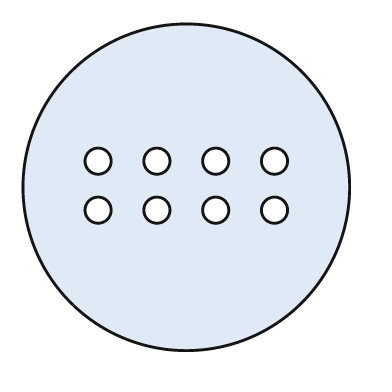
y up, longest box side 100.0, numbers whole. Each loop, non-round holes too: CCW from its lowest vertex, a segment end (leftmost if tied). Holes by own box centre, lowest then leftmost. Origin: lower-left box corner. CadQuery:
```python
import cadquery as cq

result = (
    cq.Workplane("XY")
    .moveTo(50.0, 50.0)
    .circle(50.0)
    .moveTo(23.0, 43.0)
    .circle(4.0)
    .moveTo(41.0, 43.0)
    .circle(4.0)
    .moveTo(59.0, 43.0)
    .circle(4.0)
    .moveTo(77.0, 43.0)
    .circle(4.0)
    .moveTo(23.0, 58.0)
    .circle(4.0)
    .moveTo(41.0, 58.0)
    .circle(4.0)
    .moveTo(59.0, 58.0)
    .circle(4.0)
    .moveTo(77.0, 58.0)
    .circle(4.0)
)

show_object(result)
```